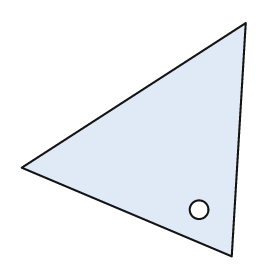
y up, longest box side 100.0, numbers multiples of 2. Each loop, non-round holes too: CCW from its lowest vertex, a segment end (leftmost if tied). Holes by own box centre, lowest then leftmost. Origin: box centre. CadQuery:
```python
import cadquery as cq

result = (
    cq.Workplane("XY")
    .moveTo(42.0, -50.0)
    .lineTo(48.0, 50.0)
    .lineTo(-48.0, -12.0)
    .close()
    .moveTo(28.0, -30.0)
    .circle(4.0)
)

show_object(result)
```